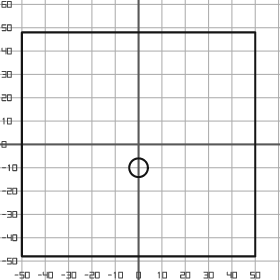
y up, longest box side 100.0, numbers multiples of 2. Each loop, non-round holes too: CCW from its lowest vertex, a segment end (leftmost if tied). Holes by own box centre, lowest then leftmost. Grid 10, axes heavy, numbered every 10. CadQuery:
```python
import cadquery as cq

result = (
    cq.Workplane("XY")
    .moveTo(-50.0, -48.0)
    .lineTo(50.0, -48.0)
    .lineTo(50.0, 48.0)
    .lineTo(-50.0, 48.0)
    .close()
    .moveTo(0.0, -10.0)
    .circle(4.0)
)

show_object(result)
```